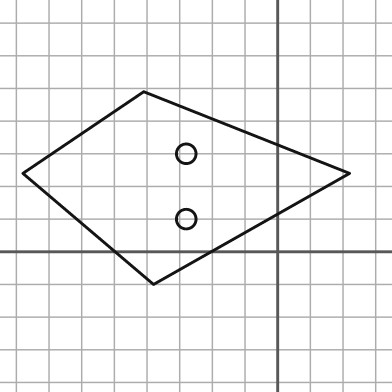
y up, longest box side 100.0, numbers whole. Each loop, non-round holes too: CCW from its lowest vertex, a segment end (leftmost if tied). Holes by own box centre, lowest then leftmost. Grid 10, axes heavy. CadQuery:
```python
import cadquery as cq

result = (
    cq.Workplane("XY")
    .moveTo(-38.0, -10.0)
    .lineTo(22.0, 24.0)
    .lineTo(-41.0, 49.0)
    .lineTo(-78.0, 24.0)
    .close()
    .moveTo(-28.0, 10.0)
    .circle(3.0)
    .moveTo(-28.0, 30.0)
    .circle(3.0)
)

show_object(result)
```